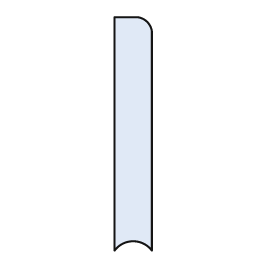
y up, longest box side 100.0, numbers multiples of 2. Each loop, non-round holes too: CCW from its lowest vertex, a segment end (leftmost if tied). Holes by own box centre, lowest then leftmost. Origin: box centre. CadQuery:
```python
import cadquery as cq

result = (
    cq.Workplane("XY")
    .moveTo(-8.0, -50.0)
    .threePointArc((0.0, -46.0), (8.0, -50.0))
    .lineTo(8.0, 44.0)
    .threePointArc((6.0, 48.0), (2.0, 50.0))
    .lineTo(-8.0, 50.0)
    .close()
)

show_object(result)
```